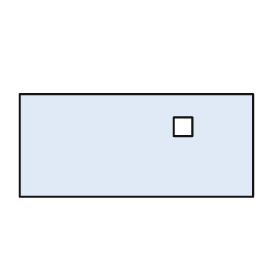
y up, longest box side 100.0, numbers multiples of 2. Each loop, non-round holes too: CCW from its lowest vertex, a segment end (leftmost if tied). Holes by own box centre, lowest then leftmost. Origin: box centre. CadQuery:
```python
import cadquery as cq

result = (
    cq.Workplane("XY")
    .moveTo(-50.0, -22.0)
    .lineTo(50.0, -22.0)
    .lineTo(50.0, 22.0)
    .lineTo(-50.0, 22.0)
    .close()
    .moveTo(16.0, 4.0)
    .lineTo(24.0, 4.0)
    .lineTo(24.0, 12.0)
    .lineTo(16.0, 12.0)
    .close()
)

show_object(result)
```